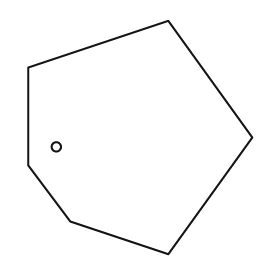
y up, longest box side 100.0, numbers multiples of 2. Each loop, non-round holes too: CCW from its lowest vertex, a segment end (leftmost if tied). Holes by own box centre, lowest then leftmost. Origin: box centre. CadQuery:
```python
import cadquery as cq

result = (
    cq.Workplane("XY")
    .moveTo(12.0, -50.0)
    .lineTo(48.0, 0.0)
    .lineTo(12.0, 50.0)
    .lineTo(-48.0, 30.0)
    .lineTo(-48.0, -12.0)
    .lineTo(-30.0, -36.0)
    .close()
    .moveTo(-36.0, -4.0)
    .circle(2.0)
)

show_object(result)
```